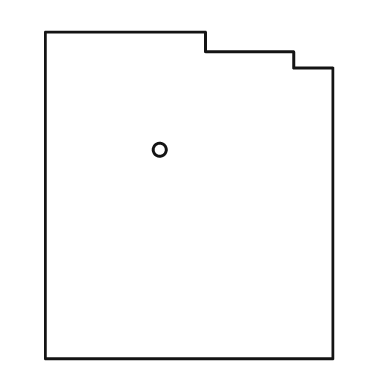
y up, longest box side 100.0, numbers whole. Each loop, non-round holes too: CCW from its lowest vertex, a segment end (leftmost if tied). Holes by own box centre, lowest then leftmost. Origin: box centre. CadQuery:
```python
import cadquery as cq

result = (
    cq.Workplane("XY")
    .moveTo(-44.0, -50.0)
    .lineTo(44.0, -50.0)
    .lineTo(44.0, 39.0)
    .lineTo(32.0, 39.0)
    .lineTo(32.0, 44.0)
    .lineTo(5.0, 44.0)
    .lineTo(5.0, 50.0)
    .lineTo(-44.0, 50.0)
    .close()
    .moveTo(-9.0, 14.0)
    .circle(2.0)
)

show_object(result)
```